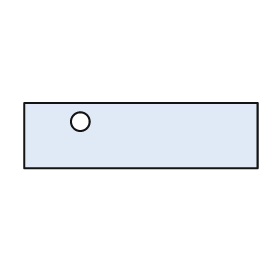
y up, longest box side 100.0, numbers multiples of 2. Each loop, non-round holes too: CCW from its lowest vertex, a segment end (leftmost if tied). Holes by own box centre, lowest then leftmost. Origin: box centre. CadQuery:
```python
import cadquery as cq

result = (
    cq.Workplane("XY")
    .moveTo(-50.0, -14.0)
    .lineTo(50.0, -14.0)
    .lineTo(50.0, 14.0)
    .lineTo(-50.0, 14.0)
    .close()
    .moveTo(-26.0, 6.0)
    .circle(4.0)
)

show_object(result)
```